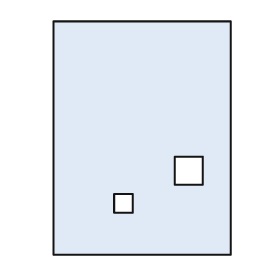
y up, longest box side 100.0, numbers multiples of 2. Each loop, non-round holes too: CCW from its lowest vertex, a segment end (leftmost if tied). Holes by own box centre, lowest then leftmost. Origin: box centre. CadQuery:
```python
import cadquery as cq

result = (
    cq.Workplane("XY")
    .moveTo(-38.0, -50.0)
    .lineTo(38.0, -50.0)
    .lineTo(38.0, 50.0)
    .lineTo(-38.0, 50.0)
    .close()
    .moveTo(-12.0, -32.0)
    .lineTo(-4.0, -32.0)
    .lineTo(-4.0, -24.0)
    .lineTo(-12.0, -24.0)
    .close()
    .moveTo(14.0, -20.0)
    .lineTo(26.0, -20.0)
    .lineTo(26.0, -8.0)
    .lineTo(14.0, -8.0)
    .close()
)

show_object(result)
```